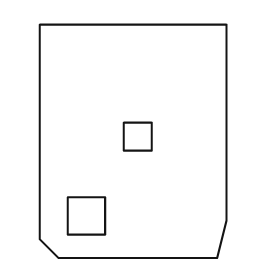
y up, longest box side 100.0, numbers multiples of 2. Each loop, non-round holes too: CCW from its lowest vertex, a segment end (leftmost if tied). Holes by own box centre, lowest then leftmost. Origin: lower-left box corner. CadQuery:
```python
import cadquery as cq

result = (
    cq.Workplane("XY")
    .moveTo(8.0, 0.0)
    .lineTo(76.0, 0.0)
    .lineTo(80.0, 16.0)
    .lineTo(80.0, 100.0)
    .lineTo(0.0, 100.0)
    .lineTo(0.0, 8.0)
    .close()
    .moveTo(12.0, 10.0)
    .lineTo(28.0, 10.0)
    .lineTo(28.0, 26.0)
    .lineTo(12.0, 26.0)
    .close()
    .moveTo(36.0, 46.0)
    .lineTo(48.0, 46.0)
    .lineTo(48.0, 58.0)
    .lineTo(36.0, 58.0)
    .close()
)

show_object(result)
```